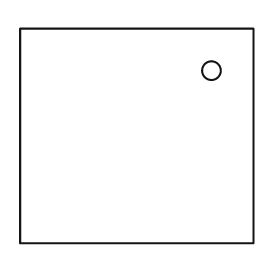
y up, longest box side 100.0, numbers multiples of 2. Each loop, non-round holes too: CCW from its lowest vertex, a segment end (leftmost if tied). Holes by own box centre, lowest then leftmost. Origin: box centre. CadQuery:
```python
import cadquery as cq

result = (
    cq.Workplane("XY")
    .moveTo(-50.0, -46.0)
    .lineTo(50.0, -46.0)
    .lineTo(50.0, 46.0)
    .lineTo(-50.0, 46.0)
    .close()
    .moveTo(32.0, 28.0)
    .circle(4.0)
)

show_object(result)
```